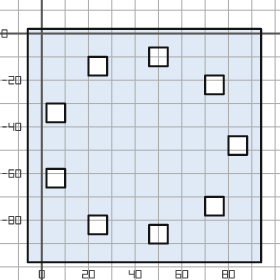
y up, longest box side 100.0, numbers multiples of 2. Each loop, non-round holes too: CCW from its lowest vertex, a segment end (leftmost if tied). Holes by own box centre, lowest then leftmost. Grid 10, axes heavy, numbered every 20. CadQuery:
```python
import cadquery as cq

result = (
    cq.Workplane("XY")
    .moveTo(-6.0, -98.0)
    .lineTo(94.0, -98.0)
    .lineTo(94.0, 2.0)
    .lineTo(-6.0, 2.0)
    .close()
    .moveTo(46.0, -90.0)
    .lineTo(54.0, -90.0)
    .lineTo(54.0, -82.0)
    .lineTo(46.0, -82.0)
    .close()
    .moveTo(20.0, -86.0)
    .lineTo(28.0, -86.0)
    .lineTo(28.0, -78.0)
    .lineTo(20.0, -78.0)
    .close()
    .moveTo(70.0, -78.0)
    .lineTo(78.0, -78.0)
    .lineTo(78.0, -70.0)
    .lineTo(70.0, -70.0)
    .close()
    .moveTo(2.0, -66.0)
    .lineTo(10.0, -66.0)
    .lineTo(10.0, -58.0)
    .lineTo(2.0, -58.0)
    .close()
    .moveTo(80.0, -52.0)
    .lineTo(88.0, -52.0)
    .lineTo(88.0, -44.0)
    .lineTo(80.0, -44.0)
    .close()
    .moveTo(2.0, -38.0)
    .lineTo(10.0, -38.0)
    .lineTo(10.0, -30.0)
    .lineTo(2.0, -30.0)
    .close()
    .moveTo(70.0, -26.0)
    .lineTo(78.0, -26.0)
    .lineTo(78.0, -18.0)
    .lineTo(70.0, -18.0)
    .close()
    .moveTo(20.0, -18.0)
    .lineTo(28.0, -18.0)
    .lineTo(28.0, -10.0)
    .lineTo(20.0, -10.0)
    .close()
    .moveTo(46.0, -14.0)
    .lineTo(54.0, -14.0)
    .lineTo(54.0, -6.0)
    .lineTo(46.0, -6.0)
    .close()
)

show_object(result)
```